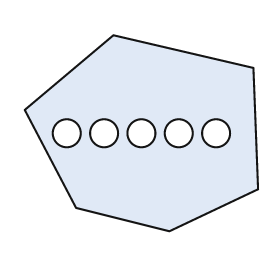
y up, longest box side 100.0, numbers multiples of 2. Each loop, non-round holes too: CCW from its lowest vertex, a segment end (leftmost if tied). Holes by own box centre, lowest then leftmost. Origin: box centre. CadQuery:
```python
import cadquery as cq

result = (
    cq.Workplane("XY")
    .moveTo(12.0, -42.0)
    .lineTo(50.0, -24.0)
    .lineTo(48.0, 28.0)
    .lineTo(-12.0, 42.0)
    .lineTo(-50.0, 10.0)
    .lineTo(-28.0, -32.0)
    .close()
    .moveTo(-32.0, 0.0)
    .circle(6.0)
    .moveTo(-16.0, 0.0)
    .circle(6.0)
    .moveTo(0.0, 0.0)
    .circle(6.0)
    .moveTo(16.0, 0.0)
    .circle(6.0)
    .moveTo(32.0, 0.0)
    .circle(6.0)
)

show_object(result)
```